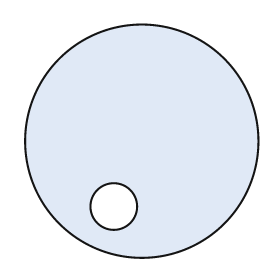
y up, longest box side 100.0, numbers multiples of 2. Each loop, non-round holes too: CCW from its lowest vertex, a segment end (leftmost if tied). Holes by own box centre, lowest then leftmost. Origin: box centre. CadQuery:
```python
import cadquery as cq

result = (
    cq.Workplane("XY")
    .moveTo(0.0, 0.0)
    .circle(50.0)
    .moveTo(-12.0, -28.0)
    .circle(10.0)
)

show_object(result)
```